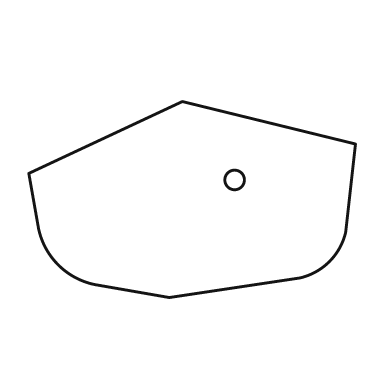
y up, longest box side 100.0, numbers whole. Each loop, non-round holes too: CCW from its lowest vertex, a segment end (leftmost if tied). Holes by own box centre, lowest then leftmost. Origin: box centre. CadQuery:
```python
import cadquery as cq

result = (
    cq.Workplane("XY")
    .moveTo(-7.0, -30.0)
    .lineTo(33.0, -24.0)
    .threePointArc((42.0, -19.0), (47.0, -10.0))
    .lineTo(50.0, 17.0)
    .lineTo(-3.0, 30.0)
    .lineTo(-50.0, 8.0)
    .lineTo(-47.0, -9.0)
    .threePointArc((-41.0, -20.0), (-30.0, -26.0))
    .close()
    .moveTo(13.0, 6.0)
    .circle(3.0)
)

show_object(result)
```